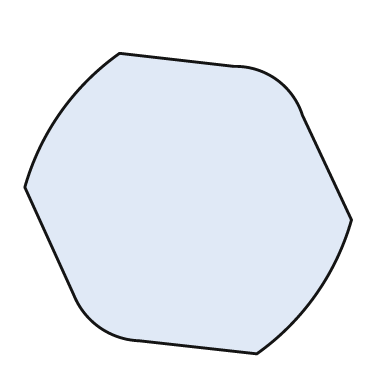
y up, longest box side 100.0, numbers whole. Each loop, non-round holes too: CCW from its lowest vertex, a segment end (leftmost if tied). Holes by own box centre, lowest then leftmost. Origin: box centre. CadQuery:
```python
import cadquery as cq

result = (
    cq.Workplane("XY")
    .moveTo(21.0, -46.0)
    .threePointArc((39.0, -28.0), (50.0, -5.0))
    .lineTo(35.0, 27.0)
    .threePointArc((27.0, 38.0), (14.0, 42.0))
    .lineTo(-21.0, 46.0)
    .threePointArc((-39.0, 28.0), (-50.0, 5.0))
    .lineTo(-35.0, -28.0)
    .threePointArc((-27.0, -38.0), (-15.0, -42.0))
    .close()
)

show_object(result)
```